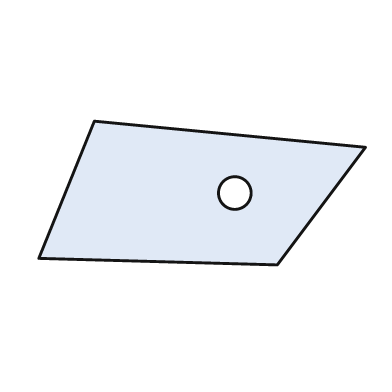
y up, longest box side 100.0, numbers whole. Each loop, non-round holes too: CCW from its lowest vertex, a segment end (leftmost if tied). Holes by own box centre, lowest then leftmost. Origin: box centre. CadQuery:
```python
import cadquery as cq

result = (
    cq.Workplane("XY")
    .moveTo(23.0, -22.0)
    .lineTo(50.0, 14.0)
    .lineTo(-33.0, 22.0)
    .lineTo(-50.0, -20.0)
    .close()
    .moveTo(10.0, 0.0)
    .circle(5.0)
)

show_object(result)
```